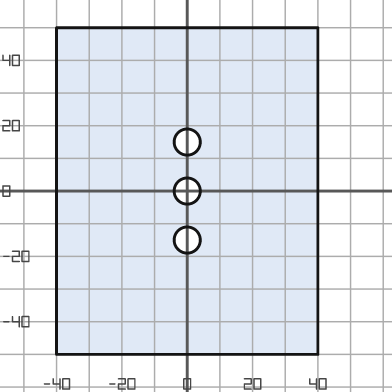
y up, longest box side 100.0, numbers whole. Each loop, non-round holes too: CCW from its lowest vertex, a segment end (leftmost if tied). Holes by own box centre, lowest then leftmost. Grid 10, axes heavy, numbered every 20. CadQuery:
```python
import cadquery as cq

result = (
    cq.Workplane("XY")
    .moveTo(-40.0, -50.0)
    .lineTo(40.0, -50.0)
    .lineTo(40.0, 50.0)
    .lineTo(-40.0, 50.0)
    .close()
    .moveTo(0.0, -15.0)
    .circle(4.0)
    .moveTo(0.0, 0.0)
    .circle(4.0)
    .moveTo(0.0, 15.0)
    .circle(4.0)
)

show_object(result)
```